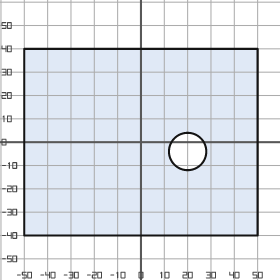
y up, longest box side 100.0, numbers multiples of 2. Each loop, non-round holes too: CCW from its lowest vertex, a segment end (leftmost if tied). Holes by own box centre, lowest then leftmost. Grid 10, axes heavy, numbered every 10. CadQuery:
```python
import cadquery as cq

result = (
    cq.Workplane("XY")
    .moveTo(-50.0, -40.0)
    .lineTo(50.0, -40.0)
    .lineTo(50.0, 40.0)
    .lineTo(-50.0, 40.0)
    .close()
    .moveTo(20.0, -4.0)
    .circle(8.0)
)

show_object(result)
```